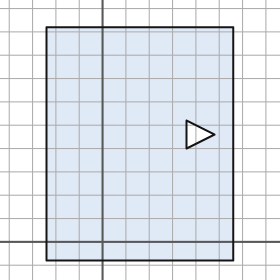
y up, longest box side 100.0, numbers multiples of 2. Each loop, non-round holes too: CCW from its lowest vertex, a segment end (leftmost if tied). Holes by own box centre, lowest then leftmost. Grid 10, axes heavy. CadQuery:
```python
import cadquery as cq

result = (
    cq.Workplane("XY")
    .moveTo(-24.0, -8.0)
    .lineTo(56.0, -8.0)
    .lineTo(56.0, 92.0)
    .lineTo(-24.0, 92.0)
    .close()
    .moveTo(36.0, 40.0)
    .lineTo(48.0, 46.0)
    .lineTo(36.0, 52.0)
    .close()
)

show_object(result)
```